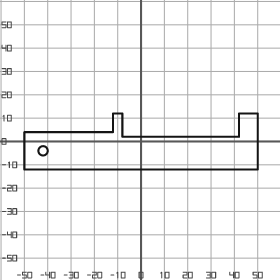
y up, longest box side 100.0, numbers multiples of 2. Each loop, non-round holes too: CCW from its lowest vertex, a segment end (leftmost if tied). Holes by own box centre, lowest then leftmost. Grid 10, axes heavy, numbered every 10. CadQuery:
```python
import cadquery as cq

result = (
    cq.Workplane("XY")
    .moveTo(-50.0, -12.0)
    .lineTo(50.0, -12.0)
    .lineTo(50.0, 12.0)
    .lineTo(42.0, 12.0)
    .lineTo(42.0, 2.0)
    .lineTo(-8.0, 2.0)
    .lineTo(-8.0, 12.0)
    .lineTo(-12.0, 12.0)
    .lineTo(-12.0, 4.0)
    .lineTo(-50.0, 4.0)
    .close()
    .moveTo(-42.0, -4.0)
    .circle(2.0)
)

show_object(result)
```